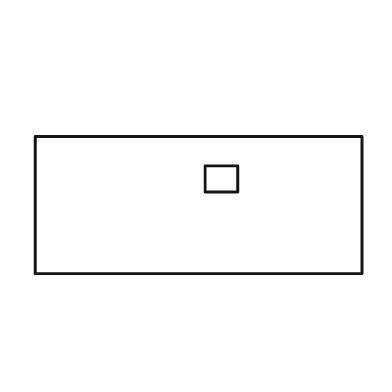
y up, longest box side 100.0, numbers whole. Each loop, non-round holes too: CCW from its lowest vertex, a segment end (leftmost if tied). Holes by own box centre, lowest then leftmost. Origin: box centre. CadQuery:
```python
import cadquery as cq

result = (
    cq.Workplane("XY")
    .moveTo(-50.0, -21.0)
    .lineTo(50.0, -21.0)
    .lineTo(50.0, 21.0)
    .lineTo(-50.0, 21.0)
    .close()
    .moveTo(2.0, 4.0)
    .lineTo(12.0, 4.0)
    .lineTo(12.0, 12.0)
    .lineTo(2.0, 12.0)
    .close()
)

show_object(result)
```